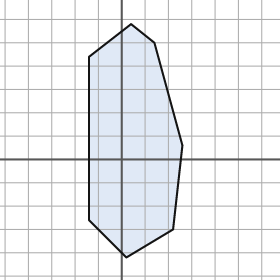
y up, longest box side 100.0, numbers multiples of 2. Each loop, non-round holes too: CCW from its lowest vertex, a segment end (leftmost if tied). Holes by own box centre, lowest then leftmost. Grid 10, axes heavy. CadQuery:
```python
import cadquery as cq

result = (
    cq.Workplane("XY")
    .moveTo(2.0, -42.0)
    .lineTo(22.0, -30.0)
    .lineTo(26.0, 6.0)
    .lineTo(14.0, 50.0)
    .lineTo(4.0, 58.0)
    .lineTo(-14.0, 44.0)
    .lineTo(-14.0, -26.0)
    .close()
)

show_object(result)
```